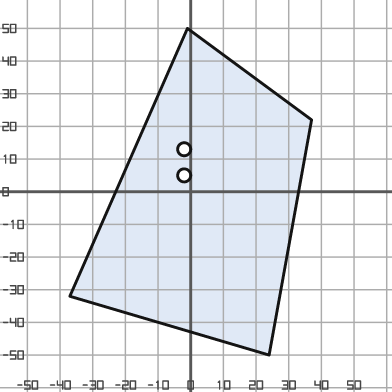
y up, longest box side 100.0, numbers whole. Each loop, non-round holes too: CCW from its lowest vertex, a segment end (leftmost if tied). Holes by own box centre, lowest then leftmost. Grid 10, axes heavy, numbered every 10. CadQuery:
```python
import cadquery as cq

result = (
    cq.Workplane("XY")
    .moveTo(24.0, -50.0)
    .lineTo(37.0, 22.0)
    .lineTo(-1.0, 50.0)
    .lineTo(-37.0, -32.0)
    .close()
    .moveTo(-2.0, 5.0)
    .circle(2.0)
    .moveTo(-2.0, 13.0)
    .circle(2.0)
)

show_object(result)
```